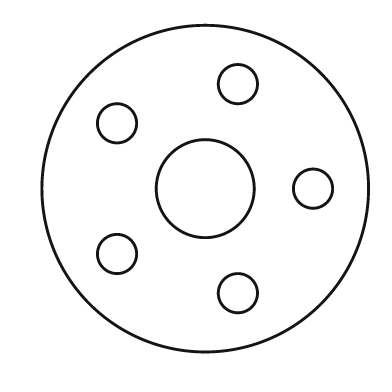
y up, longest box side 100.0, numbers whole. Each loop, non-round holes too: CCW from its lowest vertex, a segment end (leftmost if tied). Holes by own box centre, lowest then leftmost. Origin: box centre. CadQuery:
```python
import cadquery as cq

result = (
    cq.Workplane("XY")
    .moveTo(0.0, 0.0)
    .circle(50.0)
    .moveTo(10.0, -32.0)
    .circle(6.0)
    .moveTo(-27.0, -20.0)
    .circle(6.0)
    .moveTo(0.0, 0.0)
    .circle(15.0)
    .moveTo(33.0, 0.0)
    .circle(6.0)
    .moveTo(-27.0, 20.0)
    .circle(6.0)
    .moveTo(10.0, 32.0)
    .circle(6.0)
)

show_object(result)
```